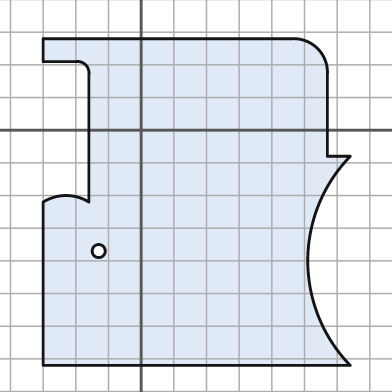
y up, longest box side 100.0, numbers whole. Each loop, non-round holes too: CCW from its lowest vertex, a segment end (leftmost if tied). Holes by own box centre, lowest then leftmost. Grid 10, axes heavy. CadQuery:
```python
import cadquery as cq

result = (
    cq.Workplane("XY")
    .moveTo(-30.0, -72.0)
    .lineTo(64.0, -72.0)
    .threePointArc((51.0, -40.0), (64.0, -8.0))
    .lineTo(57.0, -8.0)
    .lineTo(57.0, 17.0)
    .threePointArc((54.0, 25.0), (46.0, 28.0))
    .lineTo(-30.0, 28.0)
    .lineTo(-30.0, 21.0)
    .lineTo(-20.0, 21.0)
    .threePointArc((-17.0, 20.0), (-16.0, 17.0))
    .lineTo(-16.0, -22.0)
    .threePointArc((-23.0, -20.0), (-30.0, -22.0))
    .close()
    .moveTo(-13.0, -37.0)
    .circle(2.0)
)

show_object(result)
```